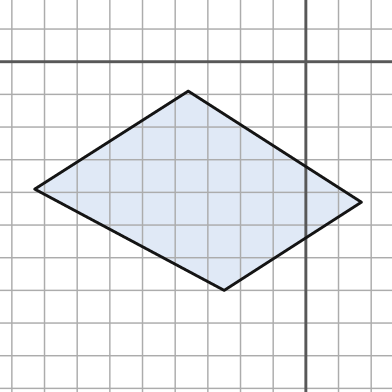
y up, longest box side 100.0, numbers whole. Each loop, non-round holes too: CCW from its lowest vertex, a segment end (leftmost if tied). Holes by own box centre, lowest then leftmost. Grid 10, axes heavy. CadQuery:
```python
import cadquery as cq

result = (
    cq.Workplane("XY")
    .moveTo(-25.0, -70.0)
    .lineTo(17.0, -43.0)
    .lineTo(-36.0, -9.0)
    .lineTo(-83.0, -39.0)
    .close()
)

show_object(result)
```